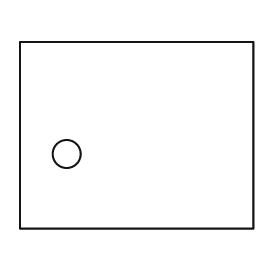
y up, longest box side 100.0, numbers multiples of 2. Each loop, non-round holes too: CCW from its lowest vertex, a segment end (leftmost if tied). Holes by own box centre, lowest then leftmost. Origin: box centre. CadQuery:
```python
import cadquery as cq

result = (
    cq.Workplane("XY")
    .moveTo(-50.0, -40.0)
    .lineTo(50.0, -40.0)
    .lineTo(50.0, 40.0)
    .lineTo(-50.0, 40.0)
    .close()
    .moveTo(-30.0, -8.0)
    .circle(6.0)
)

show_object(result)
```